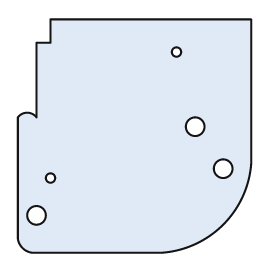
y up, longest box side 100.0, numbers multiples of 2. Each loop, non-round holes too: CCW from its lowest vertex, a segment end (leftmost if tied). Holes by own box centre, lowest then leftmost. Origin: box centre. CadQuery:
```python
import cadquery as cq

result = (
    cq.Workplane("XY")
    .moveTo(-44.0, -50.0)
    .lineTo(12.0, -50.0)
    .threePointArc((38.0, -38.0), (50.0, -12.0))
    .lineTo(50.0, 50.0)
    .lineTo(-36.0, 50.0)
    .lineTo(-36.0, 40.0)
    .lineTo(-42.0, 40.0)
    .lineTo(-42.0, 8.0)
    .threePointArc((-46.0, 10.0), (-50.0, 8.0))
    .lineTo(-50.0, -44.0)
    .threePointArc((-48.0, -48.0), (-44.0, -50.0))
    .close()
    .moveTo(-42.0, -34.0)
    .circle(4.0)
    .moveTo(-36.0, -18.0)
    .circle(2.0)
    .moveTo(38.0, -14.0)
    .circle(4.0)
    .moveTo(26.0, 4.0)
    .circle(4.0)
    .moveTo(18.0, 36.0)
    .circle(2.0)
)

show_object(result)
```